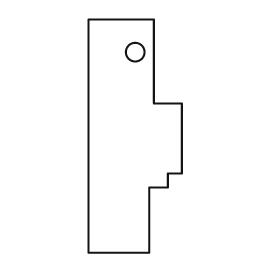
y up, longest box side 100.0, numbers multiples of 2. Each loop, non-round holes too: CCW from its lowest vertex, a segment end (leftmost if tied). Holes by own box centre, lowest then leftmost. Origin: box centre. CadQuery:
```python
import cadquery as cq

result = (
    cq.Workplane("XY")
    .moveTo(-20.0, -50.0)
    .lineTo(6.0, -50.0)
    .lineTo(6.0, -22.0)
    .lineTo(14.0, -22.0)
    .lineTo(14.0, -16.0)
    .lineTo(20.0, -16.0)
    .lineTo(20.0, 14.0)
    .lineTo(8.0, 14.0)
    .lineTo(8.0, 50.0)
    .lineTo(-20.0, 50.0)
    .close()
    .moveTo(0.0, 36.0)
    .circle(4.0)
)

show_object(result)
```